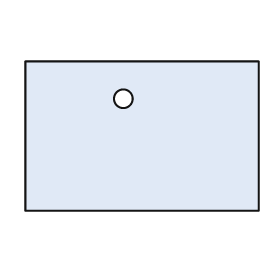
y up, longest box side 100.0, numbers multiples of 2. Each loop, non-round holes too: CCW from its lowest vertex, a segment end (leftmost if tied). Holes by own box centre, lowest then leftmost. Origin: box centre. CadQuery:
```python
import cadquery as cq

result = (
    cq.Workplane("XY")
    .moveTo(-50.0, -32.0)
    .lineTo(50.0, -32.0)
    .lineTo(50.0, 32.0)
    .lineTo(-50.0, 32.0)
    .close()
    .moveTo(-8.0, 16.0)
    .circle(4.0)
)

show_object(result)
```